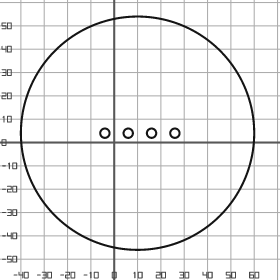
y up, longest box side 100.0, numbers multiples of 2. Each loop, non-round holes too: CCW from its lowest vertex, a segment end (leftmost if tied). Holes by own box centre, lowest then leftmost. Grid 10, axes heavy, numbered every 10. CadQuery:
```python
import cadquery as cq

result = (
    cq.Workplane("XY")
    .moveTo(10.0, 4.0)
    .circle(50.0)
    .moveTo(-4.0, 4.0)
    .circle(2.0)
    .moveTo(6.0, 4.0)
    .circle(2.0)
    .moveTo(16.0, 4.0)
    .circle(2.0)
    .moveTo(26.0, 4.0)
    .circle(2.0)
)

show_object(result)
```